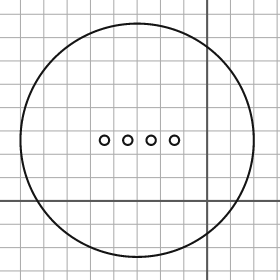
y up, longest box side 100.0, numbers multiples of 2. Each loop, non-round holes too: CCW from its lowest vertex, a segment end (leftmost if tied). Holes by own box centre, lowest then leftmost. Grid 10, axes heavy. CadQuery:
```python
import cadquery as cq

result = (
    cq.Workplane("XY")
    .moveTo(-30.0, 26.0)
    .circle(50.0)
    .moveTo(-44.0, 26.0)
    .circle(2.0)
    .moveTo(-34.0, 26.0)
    .circle(2.0)
    .moveTo(-24.0, 26.0)
    .circle(2.0)
    .moveTo(-14.0, 26.0)
    .circle(2.0)
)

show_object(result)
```